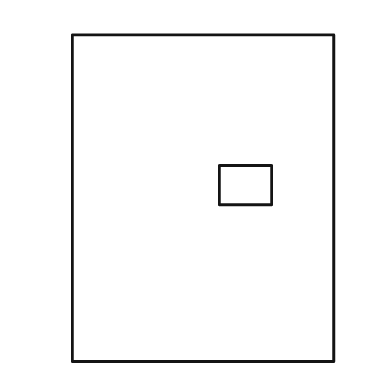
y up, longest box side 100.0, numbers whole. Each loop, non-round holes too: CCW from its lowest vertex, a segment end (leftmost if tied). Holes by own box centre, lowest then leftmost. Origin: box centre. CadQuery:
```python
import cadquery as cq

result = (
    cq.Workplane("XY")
    .moveTo(-40.0, -50.0)
    .lineTo(40.0, -50.0)
    .lineTo(40.0, 50.0)
    .lineTo(-40.0, 50.0)
    .close()
    .moveTo(5.0, -2.0)
    .lineTo(21.0, -2.0)
    .lineTo(21.0, 10.0)
    .lineTo(5.0, 10.0)
    .close()
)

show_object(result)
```